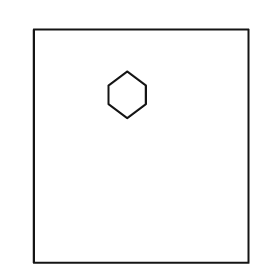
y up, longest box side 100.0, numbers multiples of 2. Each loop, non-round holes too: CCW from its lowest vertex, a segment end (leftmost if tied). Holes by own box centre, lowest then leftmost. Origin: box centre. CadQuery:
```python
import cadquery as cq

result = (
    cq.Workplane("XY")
    .moveTo(-46.0, -50.0)
    .lineTo(46.0, -50.0)
    .lineTo(46.0, 50.0)
    .lineTo(-46.0, 50.0)
    .close()
    .moveTo(-6.0, 12.0)
    .lineTo(2.0, 18.0)
    .lineTo(2.0, 26.0)
    .lineTo(-6.0, 32.0)
    .lineTo(-14.0, 26.0)
    .lineTo(-14.0, 18.0)
    .close()
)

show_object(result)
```